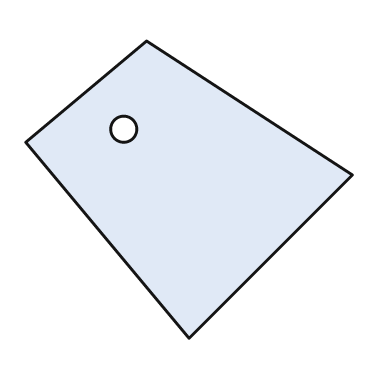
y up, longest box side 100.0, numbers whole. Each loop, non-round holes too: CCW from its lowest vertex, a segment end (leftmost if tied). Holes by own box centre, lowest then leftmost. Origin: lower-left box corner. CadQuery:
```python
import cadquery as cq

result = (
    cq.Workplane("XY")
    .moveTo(50.0, 0.0)
    .lineTo(100.0, 50.0)
    .lineTo(37.0, 91.0)
    .lineTo(0.0, 60.0)
    .close()
    .moveTo(30.0, 64.0)
    .circle(4.0)
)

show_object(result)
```